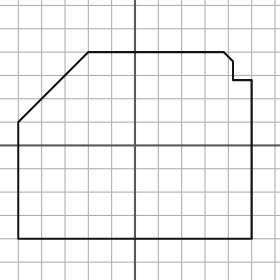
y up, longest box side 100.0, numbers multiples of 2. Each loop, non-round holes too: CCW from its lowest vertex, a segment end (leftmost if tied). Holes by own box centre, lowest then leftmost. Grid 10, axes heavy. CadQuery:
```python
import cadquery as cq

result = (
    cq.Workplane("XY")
    .moveTo(-50.0, -40.0)
    .lineTo(50.0, -40.0)
    .lineTo(50.0, 28.0)
    .lineTo(42.0, 28.0)
    .lineTo(42.0, 36.0)
    .lineTo(38.0, 40.0)
    .lineTo(-20.0, 40.0)
    .lineTo(-50.0, 10.0)
    .close()
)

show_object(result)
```